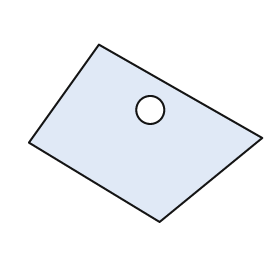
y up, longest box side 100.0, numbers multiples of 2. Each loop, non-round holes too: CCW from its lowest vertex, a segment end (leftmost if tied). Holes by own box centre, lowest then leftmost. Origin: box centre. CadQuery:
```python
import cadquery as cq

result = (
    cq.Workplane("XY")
    .moveTo(6.0, -38.0)
    .lineTo(50.0, -2.0)
    .lineTo(-20.0, 38.0)
    .lineTo(-50.0, -4.0)
    .close()
    .moveTo(2.0, 10.0)
    .circle(6.0)
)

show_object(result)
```